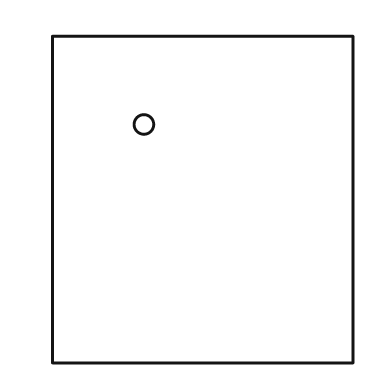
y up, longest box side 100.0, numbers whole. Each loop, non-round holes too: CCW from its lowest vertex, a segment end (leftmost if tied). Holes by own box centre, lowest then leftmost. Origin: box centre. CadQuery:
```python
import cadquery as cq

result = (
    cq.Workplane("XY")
    .moveTo(-46.0, -50.0)
    .lineTo(46.0, -50.0)
    .lineTo(46.0, 50.0)
    .lineTo(-46.0, 50.0)
    .close()
    .moveTo(-18.0, 23.0)
    .circle(3.0)
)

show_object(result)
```